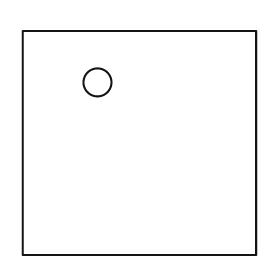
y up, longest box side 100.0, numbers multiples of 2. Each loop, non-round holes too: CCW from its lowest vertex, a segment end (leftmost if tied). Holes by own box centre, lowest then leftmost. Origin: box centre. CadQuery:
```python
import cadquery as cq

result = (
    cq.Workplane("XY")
    .moveTo(-50.0, -48.0)
    .lineTo(50.0, -48.0)
    .lineTo(50.0, 48.0)
    .lineTo(-50.0, 48.0)
    .close()
    .moveTo(-18.0, 26.0)
    .circle(6.0)
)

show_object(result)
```